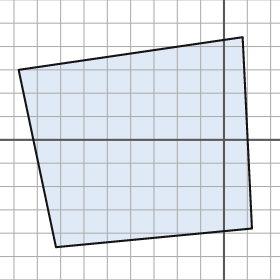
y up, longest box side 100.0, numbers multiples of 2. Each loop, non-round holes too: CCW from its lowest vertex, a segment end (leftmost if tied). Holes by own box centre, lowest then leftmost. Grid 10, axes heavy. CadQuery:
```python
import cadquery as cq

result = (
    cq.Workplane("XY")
    .moveTo(-72.0, -46.0)
    .lineTo(12.0, -38.0)
    .lineTo(8.0, 44.0)
    .lineTo(-88.0, 30.0)
    .close()
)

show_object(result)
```